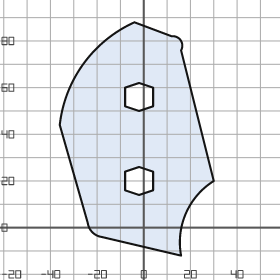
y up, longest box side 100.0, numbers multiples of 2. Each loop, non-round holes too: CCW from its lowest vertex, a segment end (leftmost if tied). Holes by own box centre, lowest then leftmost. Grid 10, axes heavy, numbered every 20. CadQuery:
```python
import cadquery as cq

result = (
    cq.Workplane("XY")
    .moveTo(16.0, -12.0)
    .threePointArc((18.0, 6.0), (30.0, 20.0))
    .lineTo(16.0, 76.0)
    .threePointArc((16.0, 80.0), (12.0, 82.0))
    .lineTo(-4.0, 88.0)
    .threePointArc((-26.0, 70.0), (-36.0, 44.0))
    .lineTo(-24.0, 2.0)
    .threePointArc((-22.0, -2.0), (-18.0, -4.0))
    .close()
    .moveTo(-2.0, 14.0)
    .lineTo(4.0, 16.0)
    .lineTo(4.0, 24.0)
    .lineTo(-2.0, 26.0)
    .lineTo(-8.0, 24.0)
    .lineTo(-8.0, 16.0)
    .close()
    .moveTo(-2.0, 50.0)
    .lineTo(4.0, 52.0)
    .lineTo(4.0, 60.0)
    .lineTo(-2.0, 62.0)
    .lineTo(-8.0, 60.0)
    .lineTo(-8.0, 52.0)
    .close()
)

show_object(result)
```